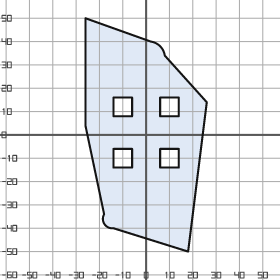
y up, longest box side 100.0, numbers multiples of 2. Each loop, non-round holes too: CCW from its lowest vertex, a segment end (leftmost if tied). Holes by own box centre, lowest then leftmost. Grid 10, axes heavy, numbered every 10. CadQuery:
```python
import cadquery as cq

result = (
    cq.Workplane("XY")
    .moveTo(18.0, -50.0)
    .lineTo(26.0, 14.0)
    .lineTo(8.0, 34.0)
    .threePointArc((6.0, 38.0), (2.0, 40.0))
    .lineTo(-26.0, 50.0)
    .lineTo(-26.0, 4.0)
    .lineTo(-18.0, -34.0)
    .threePointArc((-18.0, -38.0), (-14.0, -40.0))
    .close()
    .moveTo(-14.0, -14.0)
    .lineTo(-6.0, -14.0)
    .lineTo(-6.0, -6.0)
    .lineTo(-14.0, -6.0)
    .close()
    .moveTo(6.0, -14.0)
    .lineTo(14.0, -14.0)
    .lineTo(14.0, -6.0)
    .lineTo(6.0, -6.0)
    .close()
    .moveTo(-14.0, 8.0)
    .lineTo(-6.0, 8.0)
    .lineTo(-6.0, 16.0)
    .lineTo(-14.0, 16.0)
    .close()
    .moveTo(6.0, 8.0)
    .lineTo(14.0, 8.0)
    .lineTo(14.0, 16.0)
    .lineTo(6.0, 16.0)
    .close()
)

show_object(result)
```